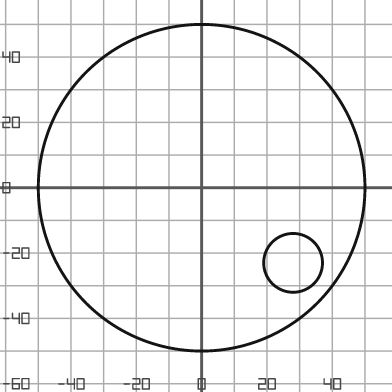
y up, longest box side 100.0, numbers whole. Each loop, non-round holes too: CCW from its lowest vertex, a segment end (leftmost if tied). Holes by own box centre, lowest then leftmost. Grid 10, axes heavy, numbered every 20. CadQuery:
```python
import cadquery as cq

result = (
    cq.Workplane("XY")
    .moveTo(0.0, 0.0)
    .circle(50.0)
    .moveTo(28.0, -23.0)
    .circle(9.0)
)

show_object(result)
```